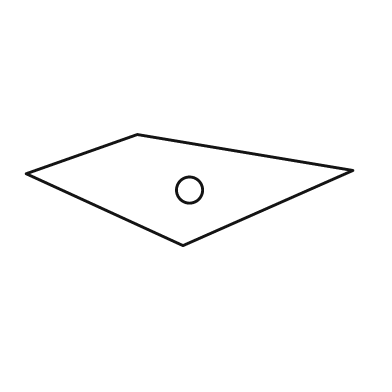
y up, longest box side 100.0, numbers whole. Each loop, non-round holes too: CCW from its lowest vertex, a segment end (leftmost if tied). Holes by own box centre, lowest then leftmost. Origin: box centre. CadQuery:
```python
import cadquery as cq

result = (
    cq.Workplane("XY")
    .moveTo(-2.0, -17.0)
    .lineTo(50.0, 6.0)
    .lineTo(-16.0, 17.0)
    .lineTo(-50.0, 5.0)
    .close()
    .moveTo(0.0, 0.0)
    .circle(4.0)
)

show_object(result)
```